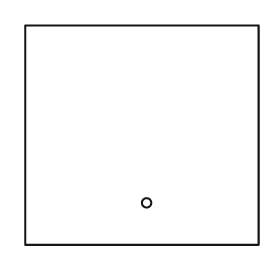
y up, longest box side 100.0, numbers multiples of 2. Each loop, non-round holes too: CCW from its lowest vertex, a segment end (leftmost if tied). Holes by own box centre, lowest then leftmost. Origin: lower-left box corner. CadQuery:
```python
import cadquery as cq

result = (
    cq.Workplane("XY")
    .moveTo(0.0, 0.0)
    .lineTo(100.0, 0.0)
    .lineTo(100.0, 94.0)
    .lineTo(0.0, 94.0)
    .close()
    .moveTo(52.0, 18.0)
    .circle(2.0)
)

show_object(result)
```